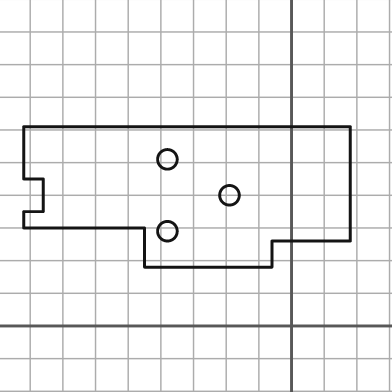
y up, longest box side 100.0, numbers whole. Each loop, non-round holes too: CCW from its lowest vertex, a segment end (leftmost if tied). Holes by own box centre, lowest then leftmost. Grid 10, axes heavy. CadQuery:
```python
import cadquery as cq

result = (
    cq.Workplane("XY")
    .moveTo(-45.0, 18.0)
    .lineTo(-6.0, 18.0)
    .lineTo(-6.0, 26.0)
    .lineTo(18.0, 26.0)
    .lineTo(18.0, 61.0)
    .lineTo(-82.0, 61.0)
    .lineTo(-82.0, 45.0)
    .lineTo(-76.0, 45.0)
    .lineTo(-76.0, 35.0)
    .lineTo(-82.0, 35.0)
    .lineTo(-82.0, 30.0)
    .lineTo(-45.0, 30.0)
    .close()
    .moveTo(-38.0, 29.0)
    .circle(3.0)
    .moveTo(-19.0, 40.0)
    .circle(3.0)
    .moveTo(-38.0, 51.0)
    .circle(3.0)
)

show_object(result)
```